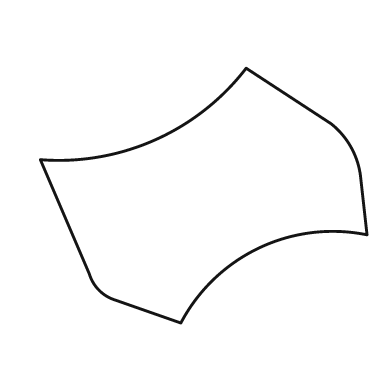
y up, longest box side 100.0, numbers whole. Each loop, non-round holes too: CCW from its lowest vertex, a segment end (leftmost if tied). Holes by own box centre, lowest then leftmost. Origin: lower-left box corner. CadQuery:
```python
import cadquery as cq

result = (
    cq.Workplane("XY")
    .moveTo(43.0, 0.0)
    .threePointArc((67.0, 23.0), (100.0, 27.0))
    .lineTo(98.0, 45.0)
    .threePointArc((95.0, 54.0), (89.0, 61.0))
    .lineTo(63.0, 78.0)
    .threePointArc((35.0, 56.0), (0.0, 50.0))
    .lineTo(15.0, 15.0)
    .threePointArc((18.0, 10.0), (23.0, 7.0))
    .close()
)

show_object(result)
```